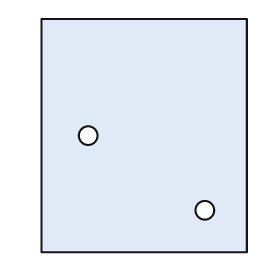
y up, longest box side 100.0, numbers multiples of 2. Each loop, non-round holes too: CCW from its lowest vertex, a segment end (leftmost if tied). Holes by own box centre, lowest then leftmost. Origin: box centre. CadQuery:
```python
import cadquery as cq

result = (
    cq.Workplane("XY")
    .moveTo(-44.0, -50.0)
    .lineTo(44.0, -50.0)
    .lineTo(44.0, 50.0)
    .lineTo(-44.0, 50.0)
    .close()
    .moveTo(26.0, -32.0)
    .circle(4.0)
    .moveTo(-24.0, 0.0)
    .circle(4.0)
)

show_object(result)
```